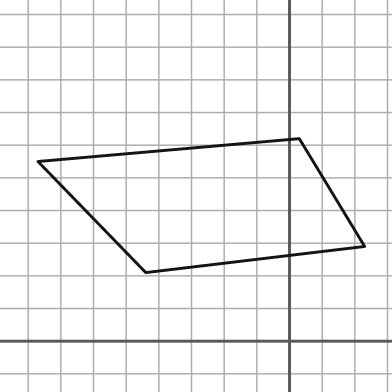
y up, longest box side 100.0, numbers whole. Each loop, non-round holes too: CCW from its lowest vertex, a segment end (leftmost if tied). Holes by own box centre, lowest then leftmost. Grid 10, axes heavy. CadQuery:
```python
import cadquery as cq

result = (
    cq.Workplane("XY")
    .moveTo(-44.0, 21.0)
    .lineTo(23.0, 29.0)
    .lineTo(3.0, 62.0)
    .lineTo(-77.0, 55.0)
    .close()
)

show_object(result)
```